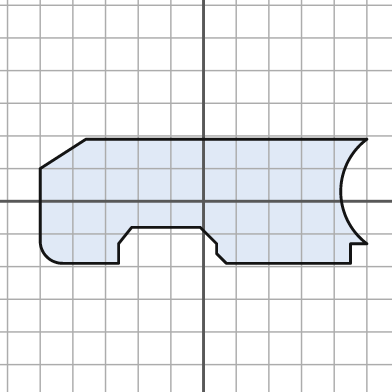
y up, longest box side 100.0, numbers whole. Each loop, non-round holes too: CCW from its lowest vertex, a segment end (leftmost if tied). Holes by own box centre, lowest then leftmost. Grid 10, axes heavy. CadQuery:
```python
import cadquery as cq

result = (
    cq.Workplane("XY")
    .moveTo(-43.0, -19.0)
    .lineTo(-26.0, -19.0)
    .lineTo(-26.0, -13.0)
    .lineTo(-22.0, -8.0)
    .lineTo(-1.0, -8.0)
    .lineTo(4.0, -13.0)
    .lineTo(4.0, -16.0)
    .lineTo(7.0, -19.0)
    .lineTo(45.0, -19.0)
    .lineTo(45.0, -13.0)
    .lineTo(50.0, -13.0)
    .threePointArc((42.0, 3.0), (50.0, 19.0))
    .lineTo(-36.0, 19.0)
    .lineTo(-50.0, 10.0)
    .lineTo(-50.0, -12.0)
    .threePointArc((-48.0, -17.0), (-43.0, -19.0))
    .close()
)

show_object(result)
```